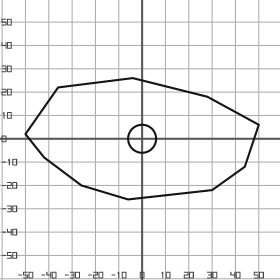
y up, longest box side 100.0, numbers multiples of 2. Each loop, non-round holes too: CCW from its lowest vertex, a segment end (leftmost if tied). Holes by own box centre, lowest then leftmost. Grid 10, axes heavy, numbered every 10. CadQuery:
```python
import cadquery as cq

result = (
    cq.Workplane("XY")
    .moveTo(-6.0, -26.0)
    .lineTo(30.0, -22.0)
    .lineTo(44.0, -12.0)
    .lineTo(50.0, 6.0)
    .lineTo(28.0, 18.0)
    .lineTo(-4.0, 26.0)
    .lineTo(-36.0, 22.0)
    .lineTo(-50.0, 2.0)
    .lineTo(-42.0, -8.0)
    .lineTo(-26.0, -20.0)
    .close()
    .moveTo(0.0, 0.0)
    .circle(6.0)
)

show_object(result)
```